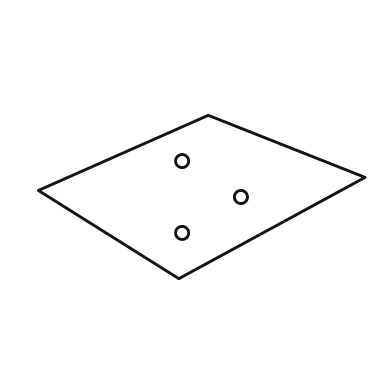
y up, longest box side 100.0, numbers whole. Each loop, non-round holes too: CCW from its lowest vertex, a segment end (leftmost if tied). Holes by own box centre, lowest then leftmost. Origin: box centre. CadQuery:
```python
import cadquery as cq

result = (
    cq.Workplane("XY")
    .moveTo(-7.0, -25.0)
    .lineTo(50.0, 6.0)
    .lineTo(2.0, 25.0)
    .lineTo(-50.0, 2.0)
    .close()
    .moveTo(-6.0, -11.0)
    .circle(2.0)
    .moveTo(12.0, 0.0)
    .circle(2.0)
    .moveTo(-6.0, 11.0)
    .circle(2.0)
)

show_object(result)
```